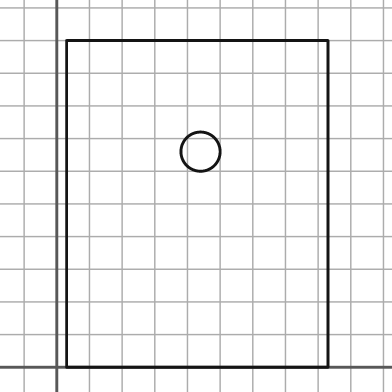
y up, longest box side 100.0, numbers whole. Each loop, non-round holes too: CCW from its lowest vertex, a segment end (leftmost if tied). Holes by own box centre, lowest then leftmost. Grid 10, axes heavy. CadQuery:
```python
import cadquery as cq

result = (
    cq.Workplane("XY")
    .moveTo(3.0, 0.0)
    .lineTo(83.0, 0.0)
    .lineTo(83.0, 100.0)
    .lineTo(3.0, 100.0)
    .close()
    .moveTo(44.0, 66.0)
    .circle(6.0)
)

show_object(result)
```